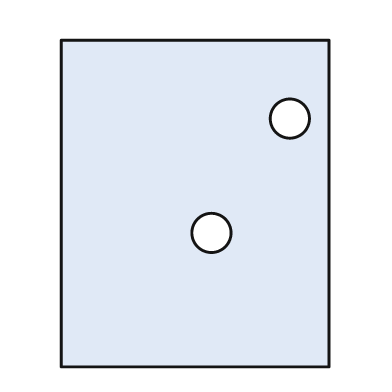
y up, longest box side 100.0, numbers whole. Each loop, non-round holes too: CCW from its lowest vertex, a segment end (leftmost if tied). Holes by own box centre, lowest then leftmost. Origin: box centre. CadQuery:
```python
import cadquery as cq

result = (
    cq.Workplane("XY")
    .moveTo(-41.0, -50.0)
    .lineTo(41.0, -50.0)
    .lineTo(41.0, 50.0)
    .lineTo(-41.0, 50.0)
    .close()
    .moveTo(5.0, -9.0)
    .circle(6.0)
    .moveTo(29.0, 26.0)
    .circle(6.0)
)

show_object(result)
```